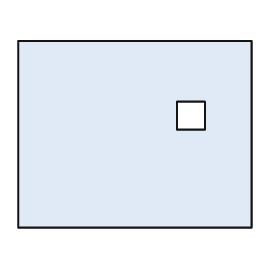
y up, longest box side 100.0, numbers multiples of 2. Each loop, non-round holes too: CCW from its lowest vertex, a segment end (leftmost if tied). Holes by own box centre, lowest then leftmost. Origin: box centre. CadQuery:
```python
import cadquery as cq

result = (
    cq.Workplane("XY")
    .moveTo(-50.0, -40.0)
    .lineTo(50.0, -40.0)
    .lineTo(50.0, 40.0)
    .lineTo(-50.0, 40.0)
    .close()
    .moveTo(18.0, 2.0)
    .lineTo(30.0, 2.0)
    .lineTo(30.0, 14.0)
    .lineTo(18.0, 14.0)
    .close()
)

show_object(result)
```